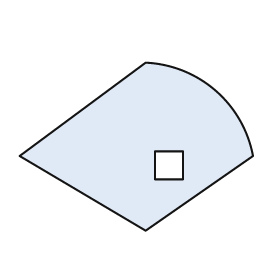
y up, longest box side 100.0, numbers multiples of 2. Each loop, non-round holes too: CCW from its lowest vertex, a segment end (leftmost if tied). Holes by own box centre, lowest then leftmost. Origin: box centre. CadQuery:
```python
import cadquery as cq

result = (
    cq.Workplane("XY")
    .moveTo(4.0, -36.0)
    .lineTo(50.0, -4.0)
    .threePointArc((34.0, 24.0), (4.0, 36.0))
    .lineTo(-50.0, -4.0)
    .close()
    .moveTo(8.0, -14.0)
    .lineTo(20.0, -14.0)
    .lineTo(20.0, -2.0)
    .lineTo(8.0, -2.0)
    .close()
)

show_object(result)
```